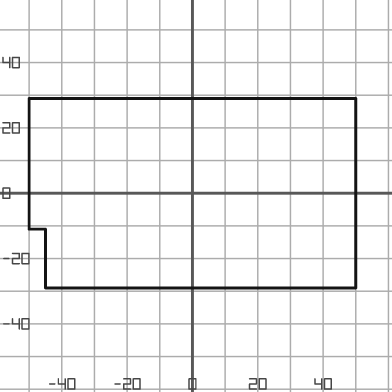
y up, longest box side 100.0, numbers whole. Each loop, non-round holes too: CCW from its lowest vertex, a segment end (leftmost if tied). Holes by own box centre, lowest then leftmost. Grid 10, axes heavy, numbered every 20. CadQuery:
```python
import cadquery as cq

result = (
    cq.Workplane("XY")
    .moveTo(-45.0, -29.0)
    .lineTo(50.0, -29.0)
    .lineTo(50.0, 29.0)
    .lineTo(-50.0, 29.0)
    .lineTo(-50.0, -11.0)
    .lineTo(-45.0, -11.0)
    .close()
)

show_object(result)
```